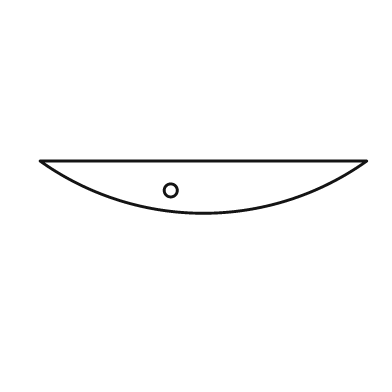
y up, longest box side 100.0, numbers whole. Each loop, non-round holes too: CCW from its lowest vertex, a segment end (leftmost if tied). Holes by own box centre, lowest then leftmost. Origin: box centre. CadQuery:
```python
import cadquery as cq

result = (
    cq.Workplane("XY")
    .moveTo(-50.0, 8.0)
    .threePointArc((0.0, -8.0), (50.0, 8.0))
    .close()
    .moveTo(-10.0, -1.0)
    .circle(2.0)
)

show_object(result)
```